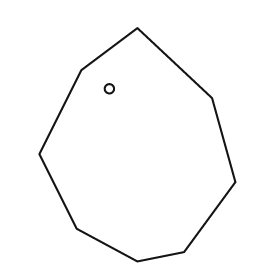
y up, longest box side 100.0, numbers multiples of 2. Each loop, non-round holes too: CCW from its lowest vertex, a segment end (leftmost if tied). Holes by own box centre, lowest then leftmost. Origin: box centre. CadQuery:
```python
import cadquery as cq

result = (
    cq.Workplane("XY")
    .moveTo(0.0, -50.0)
    .lineTo(20.0, -46.0)
    .lineTo(42.0, -16.0)
    .lineTo(32.0, 20.0)
    .lineTo(0.0, 50.0)
    .lineTo(-24.0, 32.0)
    .lineTo(-42.0, -4.0)
    .lineTo(-26.0, -36.0)
    .close()
    .moveTo(-12.0, 24.0)
    .circle(2.0)
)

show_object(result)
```